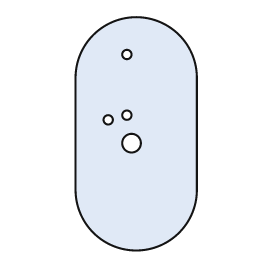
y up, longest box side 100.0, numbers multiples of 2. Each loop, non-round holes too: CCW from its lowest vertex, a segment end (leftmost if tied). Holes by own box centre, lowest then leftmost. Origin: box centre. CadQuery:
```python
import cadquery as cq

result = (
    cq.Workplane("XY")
    .moveTo(-26.0, -24.0)
    .threePointArc((0.0, -50.0), (26.0, -24.0))
    .lineTo(26.0, 24.0)
    .threePointArc((0.0, 50.0), (-26.0, 24.0))
    .close()
    .moveTo(-2.0, -4.0)
    .circle(4.0)
    .moveTo(-12.0, 6.0)
    .circle(2.0)
    .moveTo(-4.0, 8.0)
    .circle(2.0)
    .moveTo(-4.0, 34.0)
    .circle(2.0)
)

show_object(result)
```